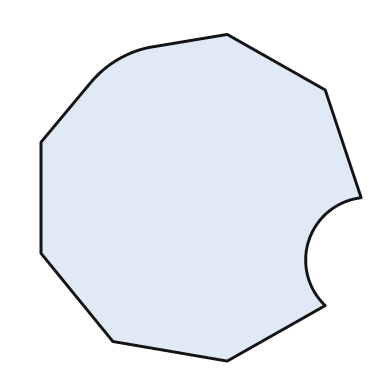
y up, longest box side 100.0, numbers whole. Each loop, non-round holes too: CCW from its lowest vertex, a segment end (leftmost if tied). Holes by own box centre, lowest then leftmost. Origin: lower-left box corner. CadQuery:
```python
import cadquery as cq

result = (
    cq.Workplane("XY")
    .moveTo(57.0, 0.0)
    .lineTo(87.0, 17.0)
    .threePointArc((82.0, 37.0), (98.0, 50.0))
    .lineTo(87.0, 83.0)
    .lineTo(57.0, 100.0)
    .lineTo(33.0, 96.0)
    .threePointArc((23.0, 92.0), (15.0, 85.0))
    .lineTo(0.0, 67.0)
    .lineTo(0.0, 33.0)
    .lineTo(22.0, 6.0)
    .close()
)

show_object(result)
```